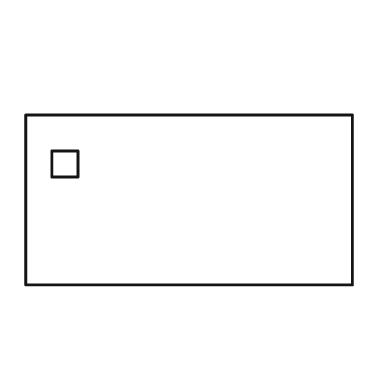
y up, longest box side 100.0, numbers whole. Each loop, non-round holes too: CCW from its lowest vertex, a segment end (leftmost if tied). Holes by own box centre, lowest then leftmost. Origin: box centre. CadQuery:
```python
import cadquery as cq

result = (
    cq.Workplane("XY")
    .moveTo(-50.0, -26.0)
    .lineTo(50.0, -26.0)
    .lineTo(50.0, 26.0)
    .lineTo(-50.0, 26.0)
    .close()
    .moveTo(-42.0, 7.0)
    .lineTo(-34.0, 7.0)
    .lineTo(-34.0, 15.0)
    .lineTo(-42.0, 15.0)
    .close()
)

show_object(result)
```